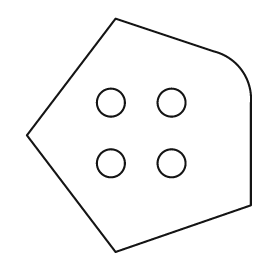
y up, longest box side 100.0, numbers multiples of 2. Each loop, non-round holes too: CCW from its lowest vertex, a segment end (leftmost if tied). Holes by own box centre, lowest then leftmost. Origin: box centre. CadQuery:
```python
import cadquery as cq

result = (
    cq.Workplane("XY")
    .moveTo(-10.0, -50.0)
    .lineTo(48.0, -30.0)
    .lineTo(48.0, 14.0)
    .threePointArc((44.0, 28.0), (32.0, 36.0))
    .lineTo(-10.0, 50.0)
    .lineTo(-48.0, 0.0)
    .close()
    .moveTo(-12.0, -12.0)
    .circle(6.0)
    .moveTo(14.0, -12.0)
    .circle(6.0)
    .moveTo(-12.0, 14.0)
    .circle(6.0)
    .moveTo(14.0, 14.0)
    .circle(6.0)
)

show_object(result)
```